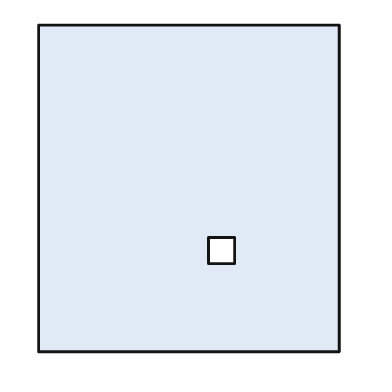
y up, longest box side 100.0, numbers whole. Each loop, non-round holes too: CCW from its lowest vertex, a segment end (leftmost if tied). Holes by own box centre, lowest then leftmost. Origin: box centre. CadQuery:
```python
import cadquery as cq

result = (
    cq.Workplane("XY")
    .moveTo(-46.0, -50.0)
    .lineTo(46.0, -50.0)
    .lineTo(46.0, 50.0)
    .lineTo(-46.0, 50.0)
    .close()
    .moveTo(6.0, -23.0)
    .lineTo(14.0, -23.0)
    .lineTo(14.0, -15.0)
    .lineTo(6.0, -15.0)
    .close()
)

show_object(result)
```